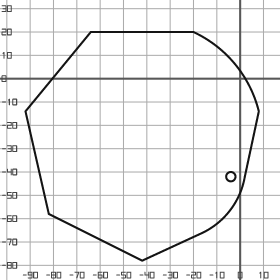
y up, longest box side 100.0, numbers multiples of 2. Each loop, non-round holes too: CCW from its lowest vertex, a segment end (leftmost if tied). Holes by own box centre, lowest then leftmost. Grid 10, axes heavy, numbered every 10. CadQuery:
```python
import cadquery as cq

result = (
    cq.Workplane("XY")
    .moveTo(-42.0, -78.0)
    .lineTo(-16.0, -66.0)
    .threePointArc((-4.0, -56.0), (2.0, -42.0))
    .lineTo(8.0, -14.0)
    .threePointArc((-2.0, 6.0), (-20.0, 20.0))
    .lineTo(-64.0, 20.0)
    .lineTo(-92.0, -14.0)
    .lineTo(-82.0, -58.0)
    .close()
    .moveTo(-4.0, -42.0)
    .circle(2.0)
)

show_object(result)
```